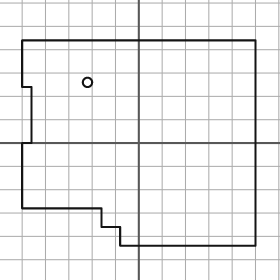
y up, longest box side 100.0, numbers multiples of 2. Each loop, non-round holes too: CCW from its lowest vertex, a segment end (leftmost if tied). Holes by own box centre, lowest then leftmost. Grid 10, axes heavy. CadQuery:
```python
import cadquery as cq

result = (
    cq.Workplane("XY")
    .moveTo(-8.0, -44.0)
    .lineTo(50.0, -44.0)
    .lineTo(50.0, 44.0)
    .lineTo(-50.0, 44.0)
    .lineTo(-50.0, 24.0)
    .lineTo(-46.0, 24.0)
    .lineTo(-46.0, 0.0)
    .lineTo(-50.0, 0.0)
    .lineTo(-50.0, -28.0)
    .lineTo(-16.0, -28.0)
    .lineTo(-16.0, -36.0)
    .lineTo(-8.0, -36.0)
    .close()
    .moveTo(-22.0, 26.0)
    .circle(2.0)
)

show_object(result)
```